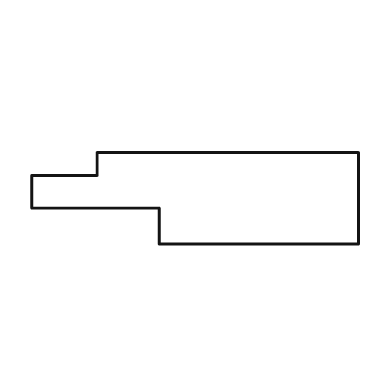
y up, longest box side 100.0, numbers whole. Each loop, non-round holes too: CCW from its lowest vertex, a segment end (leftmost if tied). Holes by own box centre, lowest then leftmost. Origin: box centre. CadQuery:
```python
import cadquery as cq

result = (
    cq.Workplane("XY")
    .moveTo(-11.0, -14.0)
    .lineTo(50.0, -14.0)
    .lineTo(50.0, 14.0)
    .lineTo(-30.0, 14.0)
    .lineTo(-30.0, 7.0)
    .lineTo(-50.0, 7.0)
    .lineTo(-50.0, -3.0)
    .lineTo(-11.0, -3.0)
    .close()
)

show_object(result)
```